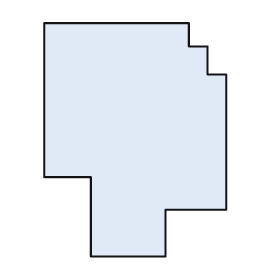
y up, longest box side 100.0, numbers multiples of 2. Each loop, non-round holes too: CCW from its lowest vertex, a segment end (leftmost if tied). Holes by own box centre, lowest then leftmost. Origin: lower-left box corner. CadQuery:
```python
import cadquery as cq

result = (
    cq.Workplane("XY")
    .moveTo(20.0, 0.0)
    .lineTo(52.0, 0.0)
    .lineTo(52.0, 20.0)
    .lineTo(78.0, 20.0)
    .lineTo(78.0, 78.0)
    .lineTo(70.0, 78.0)
    .lineTo(70.0, 90.0)
    .lineTo(62.0, 90.0)
    .lineTo(62.0, 100.0)
    .lineTo(0.0, 100.0)
    .lineTo(0.0, 34.0)
    .lineTo(20.0, 34.0)
    .close()
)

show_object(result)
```